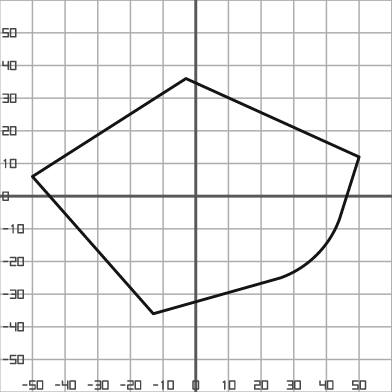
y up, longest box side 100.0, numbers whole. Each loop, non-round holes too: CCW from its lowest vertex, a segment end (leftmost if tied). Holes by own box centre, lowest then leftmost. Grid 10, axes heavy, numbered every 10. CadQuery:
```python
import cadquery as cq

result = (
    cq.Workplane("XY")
    .moveTo(-13.0, -36.0)
    .lineTo(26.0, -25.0)
    .threePointArc((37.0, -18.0), (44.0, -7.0))
    .lineTo(50.0, 12.0)
    .lineTo(-3.0, 36.0)
    .lineTo(-50.0, 6.0)
    .close()
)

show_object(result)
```